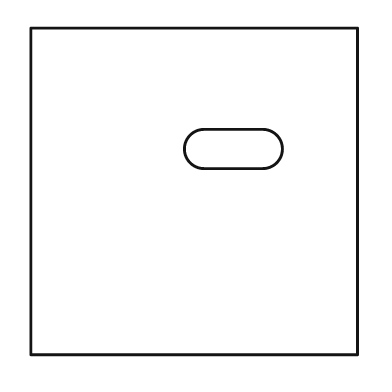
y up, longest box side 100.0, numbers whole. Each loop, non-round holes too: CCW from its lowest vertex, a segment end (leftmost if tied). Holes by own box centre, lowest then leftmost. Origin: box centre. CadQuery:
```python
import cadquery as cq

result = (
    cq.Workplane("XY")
    .moveTo(-50.0, -50.0)
    .lineTo(50.0, -50.0)
    .lineTo(50.0, 50.0)
    .lineTo(-50.0, 50.0)
    .close()
    .moveTo(3.0, 7.0)
    .lineTo(21.0, 7.0)
    .threePointArc((27.0, 13.0), (21.0, 19.0))
    .lineTo(3.0, 19.0)
    .threePointArc((-3.0, 13.0), (3.0, 7.0))
    .close()
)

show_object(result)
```